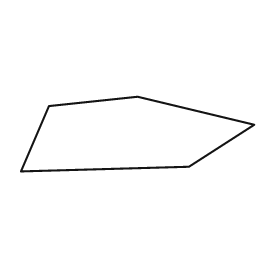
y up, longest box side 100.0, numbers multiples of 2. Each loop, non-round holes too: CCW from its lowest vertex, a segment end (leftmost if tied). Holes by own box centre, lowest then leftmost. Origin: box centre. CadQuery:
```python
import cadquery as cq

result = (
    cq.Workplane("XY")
    .moveTo(-50.0, -16.0)
    .lineTo(22.0, -14.0)
    .lineTo(50.0, 4.0)
    .lineTo(0.0, 16.0)
    .lineTo(-38.0, 12.0)
    .close()
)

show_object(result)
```